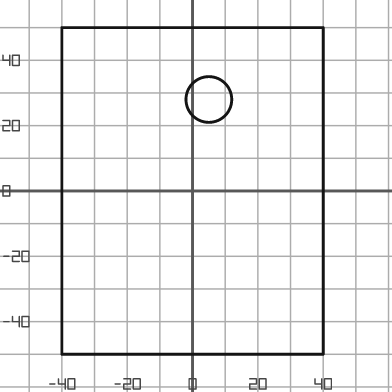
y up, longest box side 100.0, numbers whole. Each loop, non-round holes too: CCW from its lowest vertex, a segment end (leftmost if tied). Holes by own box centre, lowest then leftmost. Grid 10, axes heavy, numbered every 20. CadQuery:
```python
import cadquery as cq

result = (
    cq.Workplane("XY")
    .moveTo(-40.0, -50.0)
    .lineTo(40.0, -50.0)
    .lineTo(40.0, 50.0)
    .lineTo(-40.0, 50.0)
    .close()
    .moveTo(5.0, 28.0)
    .circle(7.0)
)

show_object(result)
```